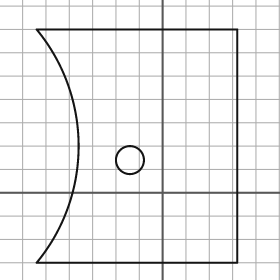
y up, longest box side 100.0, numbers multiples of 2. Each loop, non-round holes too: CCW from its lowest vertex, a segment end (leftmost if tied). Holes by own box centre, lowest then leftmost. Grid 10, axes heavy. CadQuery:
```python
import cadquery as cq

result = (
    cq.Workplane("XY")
    .moveTo(-54.0, -30.0)
    .lineTo(32.0, -30.0)
    .lineTo(32.0, 70.0)
    .lineTo(-54.0, 70.0)
    .threePointArc((-36.0, 20.0), (-54.0, -30.0))
    .close()
    .moveTo(-14.0, 14.0)
    .circle(6.0)
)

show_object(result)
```